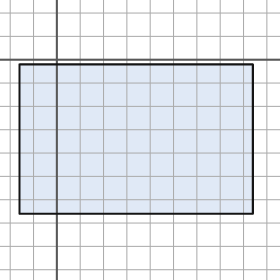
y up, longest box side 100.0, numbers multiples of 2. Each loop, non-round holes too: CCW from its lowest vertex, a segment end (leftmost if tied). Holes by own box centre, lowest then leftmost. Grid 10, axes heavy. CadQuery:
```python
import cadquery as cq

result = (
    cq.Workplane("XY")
    .moveTo(-16.0, -66.0)
    .lineTo(84.0, -66.0)
    .lineTo(84.0, -2.0)
    .lineTo(-16.0, -2.0)
    .close()
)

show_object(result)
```